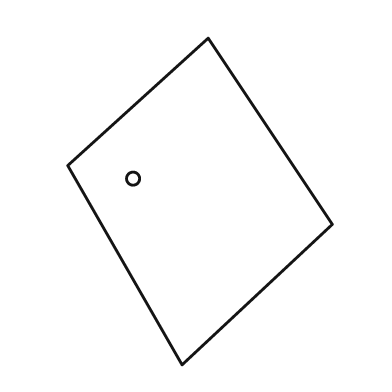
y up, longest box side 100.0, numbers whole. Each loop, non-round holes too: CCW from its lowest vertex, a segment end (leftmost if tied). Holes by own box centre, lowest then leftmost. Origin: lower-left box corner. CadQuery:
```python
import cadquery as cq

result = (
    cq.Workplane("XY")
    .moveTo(35.0, 0.0)
    .lineTo(81.0, 43.0)
    .lineTo(43.0, 100.0)
    .lineTo(0.0, 61.0)
    .close()
    .moveTo(20.0, 57.0)
    .circle(2.0)
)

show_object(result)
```